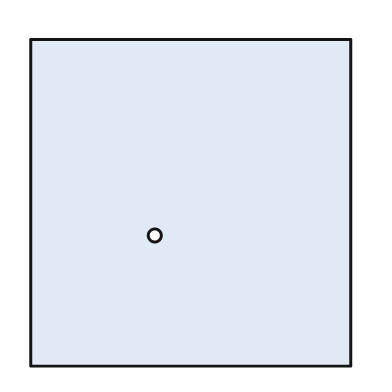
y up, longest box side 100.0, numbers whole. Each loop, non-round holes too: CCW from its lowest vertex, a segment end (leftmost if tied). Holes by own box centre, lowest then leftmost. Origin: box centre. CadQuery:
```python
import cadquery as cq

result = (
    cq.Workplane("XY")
    .moveTo(-49.0, -50.0)
    .lineTo(49.0, -50.0)
    .lineTo(49.0, 50.0)
    .lineTo(-49.0, 50.0)
    .close()
    .moveTo(-11.0, -10.0)
    .circle(2.0)
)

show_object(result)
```